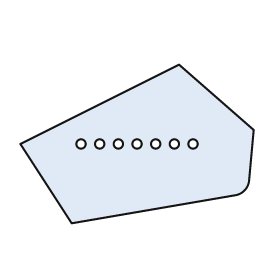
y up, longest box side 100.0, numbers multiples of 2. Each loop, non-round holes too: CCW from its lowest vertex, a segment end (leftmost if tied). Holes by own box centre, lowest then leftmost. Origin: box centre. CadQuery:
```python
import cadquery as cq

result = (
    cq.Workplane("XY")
    .moveTo(-28.0, -34.0)
    .lineTo(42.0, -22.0)
    .threePointArc((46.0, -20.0), (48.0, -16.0))
    .lineTo(50.0, 6.0)
    .lineTo(18.0, 34.0)
    .lineTo(-50.0, 0.0)
    .close()
    .moveTo(-24.0, 0.0)
    .circle(2.0)
    .moveTo(-16.0, 0.0)
    .circle(2.0)
    .moveTo(-8.0, 0.0)
    .circle(2.0)
    .moveTo(0.0, 0.0)
    .circle(2.0)
    .moveTo(8.0, 0.0)
    .circle(2.0)
    .moveTo(16.0, 0.0)
    .circle(2.0)
    .moveTo(24.0, 0.0)
    .circle(2.0)
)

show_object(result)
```